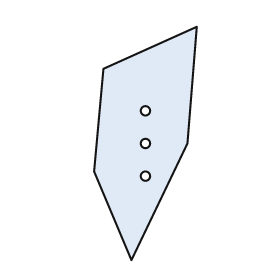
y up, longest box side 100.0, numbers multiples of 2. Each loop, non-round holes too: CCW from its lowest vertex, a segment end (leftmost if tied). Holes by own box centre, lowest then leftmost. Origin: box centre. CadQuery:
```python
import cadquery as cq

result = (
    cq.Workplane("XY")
    .moveTo(-6.0, -50.0)
    .lineTo(18.0, 0.0)
    .lineTo(22.0, 50.0)
    .lineTo(-18.0, 32.0)
    .lineTo(-22.0, -12.0)
    .close()
    .moveTo(0.0, -14.0)
    .circle(2.0)
    .moveTo(0.0, 0.0)
    .circle(2.0)
    .moveTo(0.0, 14.0)
    .circle(2.0)
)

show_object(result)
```